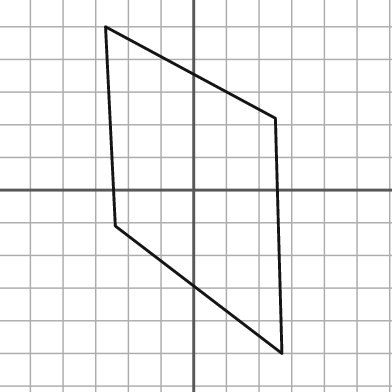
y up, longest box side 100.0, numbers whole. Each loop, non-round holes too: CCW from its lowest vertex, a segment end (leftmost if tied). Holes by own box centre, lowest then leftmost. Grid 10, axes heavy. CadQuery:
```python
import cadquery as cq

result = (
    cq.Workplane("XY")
    .moveTo(27.0, -50.0)
    .lineTo(25.0, 22.0)
    .lineTo(-27.0, 50.0)
    .lineTo(-24.0, -11.0)
    .close()
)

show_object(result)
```